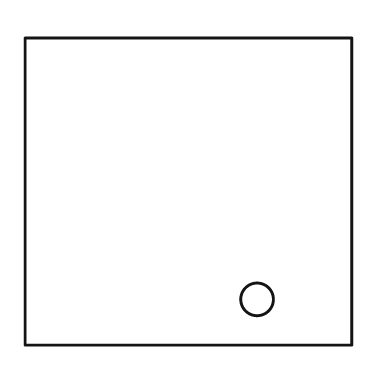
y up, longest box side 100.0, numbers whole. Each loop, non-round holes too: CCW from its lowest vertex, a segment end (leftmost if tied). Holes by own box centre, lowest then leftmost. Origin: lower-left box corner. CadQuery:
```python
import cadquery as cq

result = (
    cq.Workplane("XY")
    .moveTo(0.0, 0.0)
    .lineTo(100.0, 0.0)
    .lineTo(100.0, 94.0)
    .lineTo(0.0, 94.0)
    .close()
    .moveTo(71.0, 14.0)
    .circle(5.0)
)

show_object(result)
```